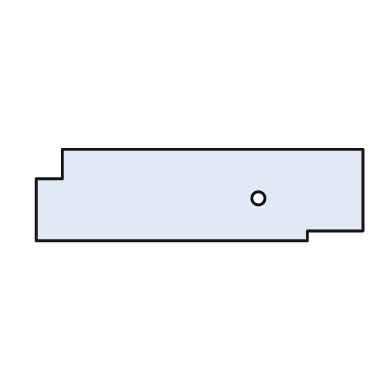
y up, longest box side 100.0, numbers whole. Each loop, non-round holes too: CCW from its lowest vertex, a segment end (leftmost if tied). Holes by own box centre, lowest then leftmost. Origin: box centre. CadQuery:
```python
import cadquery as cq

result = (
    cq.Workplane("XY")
    .moveTo(-50.0, -14.0)
    .lineTo(33.0, -14.0)
    .lineTo(33.0, -11.0)
    .lineTo(50.0, -11.0)
    .lineTo(50.0, 14.0)
    .lineTo(-42.0, 14.0)
    .lineTo(-42.0, 5.0)
    .lineTo(-50.0, 5.0)
    .close()
    .moveTo(18.0, -1.0)
    .circle(2.0)
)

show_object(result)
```